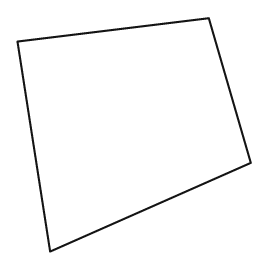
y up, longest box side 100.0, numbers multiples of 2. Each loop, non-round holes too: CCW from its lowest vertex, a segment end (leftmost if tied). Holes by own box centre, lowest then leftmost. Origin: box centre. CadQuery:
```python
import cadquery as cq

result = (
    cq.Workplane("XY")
    .moveTo(-36.0, -50.0)
    .lineTo(50.0, -12.0)
    .lineTo(32.0, 50.0)
    .lineTo(-50.0, 40.0)
    .close()
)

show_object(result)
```